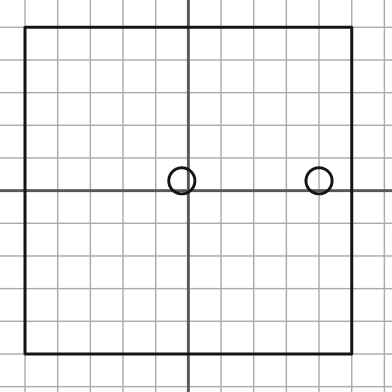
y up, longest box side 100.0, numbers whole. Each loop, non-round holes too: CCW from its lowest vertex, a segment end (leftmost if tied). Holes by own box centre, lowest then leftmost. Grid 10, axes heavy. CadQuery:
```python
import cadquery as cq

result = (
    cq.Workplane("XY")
    .moveTo(-50.0, -50.0)
    .lineTo(50.0, -50.0)
    .lineTo(50.0, 50.0)
    .lineTo(-50.0, 50.0)
    .close()
    .moveTo(-2.0, 3.0)
    .circle(4.0)
    .moveTo(40.0, 3.0)
    .circle(4.0)
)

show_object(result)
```